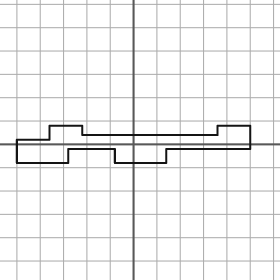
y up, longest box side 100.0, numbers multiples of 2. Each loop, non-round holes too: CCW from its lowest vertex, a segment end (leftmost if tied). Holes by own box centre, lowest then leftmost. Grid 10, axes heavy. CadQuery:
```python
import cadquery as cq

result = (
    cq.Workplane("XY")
    .moveTo(-50.0, -8.0)
    .lineTo(-28.0, -8.0)
    .lineTo(-28.0, -2.0)
    .lineTo(-8.0, -2.0)
    .lineTo(-8.0, -8.0)
    .lineTo(14.0, -8.0)
    .lineTo(14.0, -2.0)
    .lineTo(50.0, -2.0)
    .lineTo(50.0, 8.0)
    .lineTo(36.0, 8.0)
    .lineTo(36.0, 4.0)
    .lineTo(-22.0, 4.0)
    .lineTo(-22.0, 8.0)
    .lineTo(-36.0, 8.0)
    .lineTo(-36.0, 2.0)
    .lineTo(-50.0, 2.0)
    .close()
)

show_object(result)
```